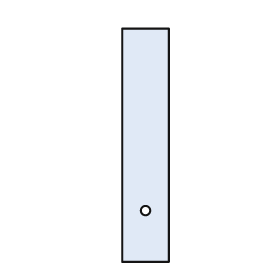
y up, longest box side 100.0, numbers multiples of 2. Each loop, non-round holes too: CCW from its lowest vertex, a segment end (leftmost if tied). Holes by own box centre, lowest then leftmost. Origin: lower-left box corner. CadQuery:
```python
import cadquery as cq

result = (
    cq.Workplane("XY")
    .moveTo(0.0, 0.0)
    .lineTo(20.0, 0.0)
    .lineTo(20.0, 100.0)
    .lineTo(0.0, 100.0)
    .close()
    .moveTo(10.0, 22.0)
    .circle(2.0)
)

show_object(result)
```